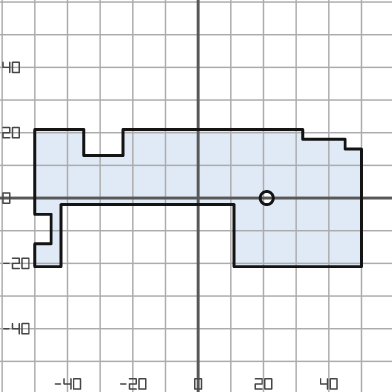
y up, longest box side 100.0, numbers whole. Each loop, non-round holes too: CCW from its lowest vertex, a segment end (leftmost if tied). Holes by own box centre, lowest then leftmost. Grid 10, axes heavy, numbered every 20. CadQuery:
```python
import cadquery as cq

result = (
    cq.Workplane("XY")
    .moveTo(-50.0, -21.0)
    .lineTo(-42.0, -21.0)
    .lineTo(-42.0, -2.0)
    .lineTo(11.0, -2.0)
    .lineTo(11.0, -21.0)
    .lineTo(50.0, -21.0)
    .lineTo(50.0, 15.0)
    .lineTo(45.0, 15.0)
    .lineTo(45.0, 18.0)
    .lineTo(32.0, 18.0)
    .lineTo(32.0, 21.0)
    .lineTo(-23.0, 21.0)
    .lineTo(-23.0, 13.0)
    .lineTo(-35.0, 13.0)
    .lineTo(-35.0, 21.0)
    .lineTo(-50.0, 21.0)
    .lineTo(-50.0, -5.0)
    .lineTo(-45.0, -5.0)
    .lineTo(-45.0, -14.0)
    .lineTo(-50.0, -14.0)
    .close()
    .moveTo(21.0, 0.0)
    .circle(2.0)
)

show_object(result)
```